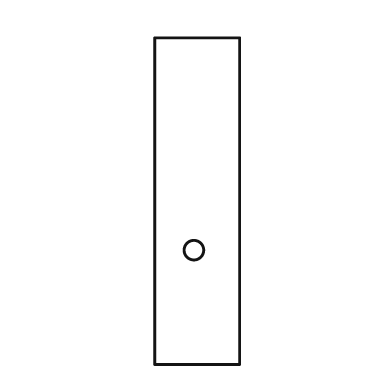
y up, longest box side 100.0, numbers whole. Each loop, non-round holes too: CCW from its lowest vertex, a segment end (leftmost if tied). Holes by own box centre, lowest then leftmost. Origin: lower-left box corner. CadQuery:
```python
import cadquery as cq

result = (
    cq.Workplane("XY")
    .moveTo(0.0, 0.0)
    .lineTo(26.0, 0.0)
    .lineTo(26.0, 100.0)
    .lineTo(0.0, 100.0)
    .close()
    .moveTo(12.0, 35.0)
    .circle(3.0)
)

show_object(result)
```